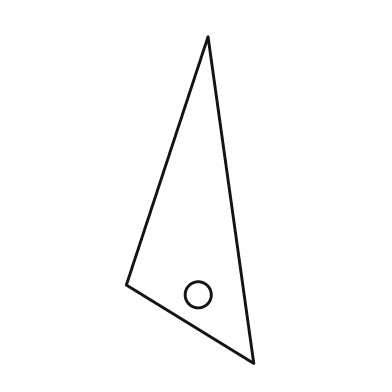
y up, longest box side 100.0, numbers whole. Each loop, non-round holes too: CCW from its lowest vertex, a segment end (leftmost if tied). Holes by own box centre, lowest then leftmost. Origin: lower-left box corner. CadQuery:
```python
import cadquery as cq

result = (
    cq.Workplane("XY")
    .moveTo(39.0, 0.0)
    .lineTo(25.0, 100.0)
    .lineTo(0.0, 24.0)
    .close()
    .moveTo(22.0, 21.0)
    .circle(4.0)
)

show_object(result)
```